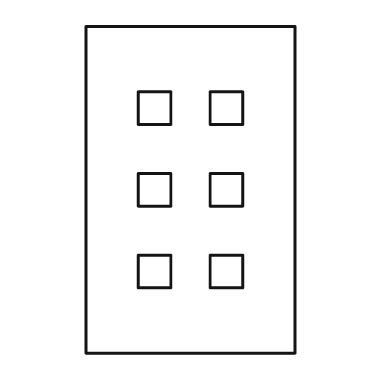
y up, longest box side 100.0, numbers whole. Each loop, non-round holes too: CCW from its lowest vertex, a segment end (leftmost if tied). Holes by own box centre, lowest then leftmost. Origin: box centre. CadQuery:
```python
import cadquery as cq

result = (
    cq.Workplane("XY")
    .moveTo(-32.0, -50.0)
    .lineTo(32.0, -50.0)
    .lineTo(32.0, 50.0)
    .lineTo(-32.0, 50.0)
    .close()
    .moveTo(-16.0, -30.0)
    .lineTo(-6.0, -30.0)
    .lineTo(-6.0, -20.0)
    .lineTo(-16.0, -20.0)
    .close()
    .moveTo(6.0, -30.0)
    .lineTo(16.0, -30.0)
    .lineTo(16.0, -20.0)
    .lineTo(6.0, -20.0)
    .close()
    .moveTo(-16.0, -5.0)
    .lineTo(-6.0, -5.0)
    .lineTo(-6.0, 5.0)
    .lineTo(-16.0, 5.0)
    .close()
    .moveTo(6.0, -5.0)
    .lineTo(16.0, -5.0)
    .lineTo(16.0, 5.0)
    .lineTo(6.0, 5.0)
    .close()
    .moveTo(-16.0, 20.0)
    .lineTo(-6.0, 20.0)
    .lineTo(-6.0, 30.0)
    .lineTo(-16.0, 30.0)
    .close()
    .moveTo(6.0, 20.0)
    .lineTo(16.0, 20.0)
    .lineTo(16.0, 30.0)
    .lineTo(6.0, 30.0)
    .close()
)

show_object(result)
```